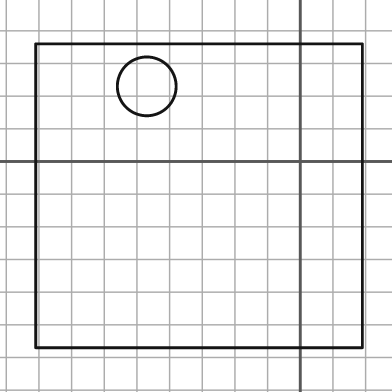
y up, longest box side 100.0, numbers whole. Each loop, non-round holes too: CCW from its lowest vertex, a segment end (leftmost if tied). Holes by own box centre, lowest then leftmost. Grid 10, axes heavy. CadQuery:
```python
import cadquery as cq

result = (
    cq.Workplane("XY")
    .moveTo(-81.0, -57.0)
    .lineTo(19.0, -57.0)
    .lineTo(19.0, 36.0)
    .lineTo(-81.0, 36.0)
    .close()
    .moveTo(-47.0, 23.0)
    .circle(9.0)
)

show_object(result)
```